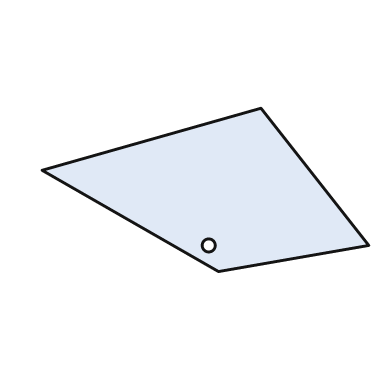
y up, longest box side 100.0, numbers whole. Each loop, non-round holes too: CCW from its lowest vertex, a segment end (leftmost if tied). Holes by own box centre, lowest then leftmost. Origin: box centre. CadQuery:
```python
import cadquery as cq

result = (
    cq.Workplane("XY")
    .moveTo(4.0, -25.0)
    .lineTo(50.0, -17.0)
    .lineTo(17.0, 25.0)
    .lineTo(-50.0, 6.0)
    .close()
    .moveTo(1.0, -17.0)
    .circle(2.0)
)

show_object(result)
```